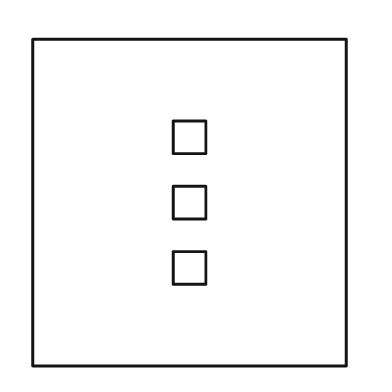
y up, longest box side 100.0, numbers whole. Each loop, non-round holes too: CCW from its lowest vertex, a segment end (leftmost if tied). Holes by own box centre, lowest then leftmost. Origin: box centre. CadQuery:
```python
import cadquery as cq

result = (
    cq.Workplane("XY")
    .moveTo(-48.0, -50.0)
    .lineTo(48.0, -50.0)
    .lineTo(48.0, 50.0)
    .lineTo(-48.0, 50.0)
    .close()
    .moveTo(-5.0, -25.0)
    .lineTo(5.0, -25.0)
    .lineTo(5.0, -15.0)
    .lineTo(-5.0, -15.0)
    .close()
    .moveTo(-5.0, -5.0)
    .lineTo(5.0, -5.0)
    .lineTo(5.0, 5.0)
    .lineTo(-5.0, 5.0)
    .close()
    .moveTo(-5.0, 15.0)
    .lineTo(5.0, 15.0)
    .lineTo(5.0, 25.0)
    .lineTo(-5.0, 25.0)
    .close()
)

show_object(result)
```